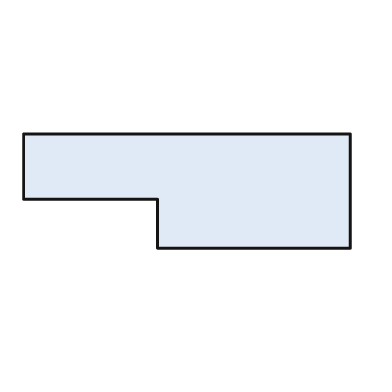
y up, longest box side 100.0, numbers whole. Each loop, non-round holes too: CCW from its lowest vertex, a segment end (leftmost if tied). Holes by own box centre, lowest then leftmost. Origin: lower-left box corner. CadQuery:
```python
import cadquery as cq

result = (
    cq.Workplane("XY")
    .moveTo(41.0, 0.0)
    .lineTo(100.0, 0.0)
    .lineTo(100.0, 35.0)
    .lineTo(0.0, 35.0)
    .lineTo(0.0, 15.0)
    .lineTo(41.0, 15.0)
    .close()
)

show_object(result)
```